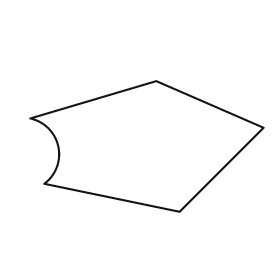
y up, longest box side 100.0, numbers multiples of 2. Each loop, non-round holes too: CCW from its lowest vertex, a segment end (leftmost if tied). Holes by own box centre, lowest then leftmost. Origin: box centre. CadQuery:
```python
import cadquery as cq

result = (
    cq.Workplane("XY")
    .moveTo(14.0, -28.0)
    .lineTo(50.0, 8.0)
    .lineTo(4.0, 28.0)
    .lineTo(-50.0, 12.0)
    .threePointArc((-38.0, 0.0), (-44.0, -16.0))
    .close()
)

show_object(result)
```